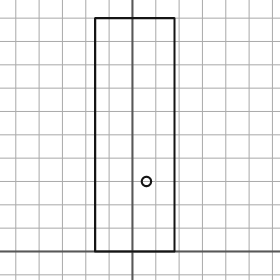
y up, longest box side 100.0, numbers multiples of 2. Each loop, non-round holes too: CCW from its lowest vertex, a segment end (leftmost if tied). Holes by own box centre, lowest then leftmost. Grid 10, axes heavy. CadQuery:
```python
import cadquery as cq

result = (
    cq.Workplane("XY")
    .moveTo(-16.0, 0.0)
    .lineTo(18.0, 0.0)
    .lineTo(18.0, 100.0)
    .lineTo(-16.0, 100.0)
    .close()
    .moveTo(6.0, 30.0)
    .circle(2.0)
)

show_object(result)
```